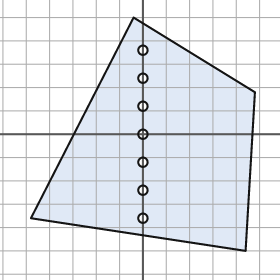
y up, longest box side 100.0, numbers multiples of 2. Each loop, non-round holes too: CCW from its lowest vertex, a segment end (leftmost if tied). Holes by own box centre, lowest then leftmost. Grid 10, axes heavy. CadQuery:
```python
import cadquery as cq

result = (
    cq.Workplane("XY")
    .moveTo(44.0, -50.0)
    .lineTo(48.0, 18.0)
    .lineTo(-4.0, 50.0)
    .lineTo(-48.0, -36.0)
    .close()
    .moveTo(0.0, -36.0)
    .circle(2.0)
    .moveTo(0.0, -24.0)
    .circle(2.0)
    .moveTo(0.0, -12.0)
    .circle(2.0)
    .moveTo(0.0, 0.0)
    .circle(2.0)
    .moveTo(0.0, 12.0)
    .circle(2.0)
    .moveTo(0.0, 24.0)
    .circle(2.0)
    .moveTo(0.0, 36.0)
    .circle(2.0)
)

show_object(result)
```